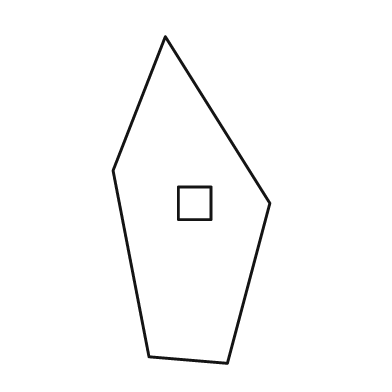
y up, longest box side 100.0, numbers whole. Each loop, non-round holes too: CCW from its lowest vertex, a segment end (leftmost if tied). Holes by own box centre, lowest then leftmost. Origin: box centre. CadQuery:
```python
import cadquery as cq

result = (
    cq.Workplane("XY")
    .moveTo(11.0, -50.0)
    .lineTo(24.0, -1.0)
    .lineTo(-8.0, 50.0)
    .lineTo(-24.0, 9.0)
    .lineTo(-13.0, -48.0)
    .close()
    .moveTo(-4.0, -6.0)
    .lineTo(6.0, -6.0)
    .lineTo(6.0, 4.0)
    .lineTo(-4.0, 4.0)
    .close()
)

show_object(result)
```